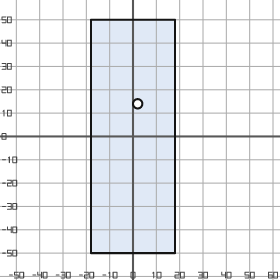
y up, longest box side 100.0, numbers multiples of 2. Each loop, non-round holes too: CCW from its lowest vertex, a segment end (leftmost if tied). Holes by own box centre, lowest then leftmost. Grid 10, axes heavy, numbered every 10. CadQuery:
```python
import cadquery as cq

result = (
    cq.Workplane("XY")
    .moveTo(-18.0, -50.0)
    .lineTo(18.0, -50.0)
    .lineTo(18.0, 50.0)
    .lineTo(-18.0, 50.0)
    .close()
    .moveTo(2.0, 14.0)
    .circle(2.0)
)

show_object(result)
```